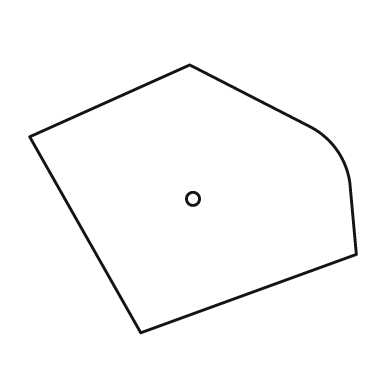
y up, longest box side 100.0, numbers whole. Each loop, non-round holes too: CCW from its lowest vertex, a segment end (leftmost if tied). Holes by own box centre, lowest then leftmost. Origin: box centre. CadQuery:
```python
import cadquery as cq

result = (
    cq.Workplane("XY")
    .moveTo(-16.0, -41.0)
    .lineTo(50.0, -17.0)
    .lineTo(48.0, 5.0)
    .threePointArc((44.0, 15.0), (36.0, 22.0))
    .lineTo(-1.0, 41.0)
    .lineTo(-50.0, 19.0)
    .close()
    .moveTo(0.0, 0.0)
    .circle(2.0)
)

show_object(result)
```